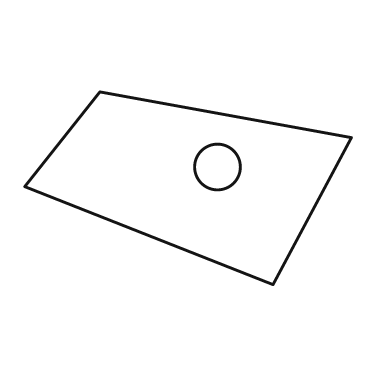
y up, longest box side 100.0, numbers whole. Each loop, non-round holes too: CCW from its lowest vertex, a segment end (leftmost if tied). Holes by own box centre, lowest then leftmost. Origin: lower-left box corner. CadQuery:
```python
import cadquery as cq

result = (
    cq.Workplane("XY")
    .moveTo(76.0, 0.0)
    .lineTo(100.0, 45.0)
    .lineTo(23.0, 59.0)
    .lineTo(0.0, 30.0)
    .close()
    .moveTo(59.0, 36.0)
    .circle(7.0)
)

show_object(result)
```